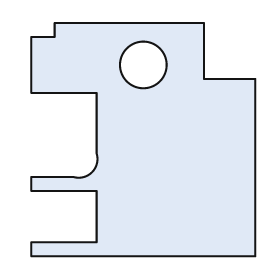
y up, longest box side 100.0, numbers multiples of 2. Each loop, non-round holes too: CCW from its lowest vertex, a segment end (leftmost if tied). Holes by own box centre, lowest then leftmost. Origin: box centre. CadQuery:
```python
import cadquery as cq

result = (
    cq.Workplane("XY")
    .moveTo(-48.0, -50.0)
    .lineTo(48.0, -50.0)
    .lineTo(48.0, 26.0)
    .lineTo(26.0, 26.0)
    .lineTo(26.0, 50.0)
    .lineTo(-38.0, 50.0)
    .lineTo(-38.0, 44.0)
    .lineTo(-48.0, 44.0)
    .lineTo(-48.0, 20.0)
    .lineTo(-20.0, 20.0)
    .lineTo(-20.0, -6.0)
    .threePointArc((-22.0, -14.0), (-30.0, -16.0))
    .lineTo(-48.0, -16.0)
    .lineTo(-48.0, -22.0)
    .lineTo(-20.0, -22.0)
    .lineTo(-20.0, -44.0)
    .lineTo(-48.0, -44.0)
    .close()
    .moveTo(0.0, 32.0)
    .circle(10.0)
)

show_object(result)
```